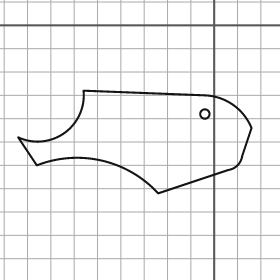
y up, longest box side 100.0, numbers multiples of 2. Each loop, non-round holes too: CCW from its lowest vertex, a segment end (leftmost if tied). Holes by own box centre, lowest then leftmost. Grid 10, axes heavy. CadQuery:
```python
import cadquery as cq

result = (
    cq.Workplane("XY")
    .moveTo(-24.0, -72.0)
    .lineTo(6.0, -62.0)
    .threePointArc((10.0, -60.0), (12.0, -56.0))
    .lineTo(16.0, -44.0)
    .threePointArc((8.0, -34.0), (-4.0, -30.0))
    .lineTo(-56.0, -28.0)
    .threePointArc((-64.0, -46.0), (-84.0, -48.0))
    .lineTo(-76.0, -60.0)
    .threePointArc((-48.0, -58.0), (-24.0, -72.0))
    .close()
    .moveTo(-4.0, -38.0)
    .circle(2.0)
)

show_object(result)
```